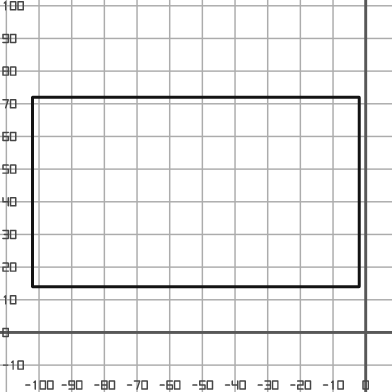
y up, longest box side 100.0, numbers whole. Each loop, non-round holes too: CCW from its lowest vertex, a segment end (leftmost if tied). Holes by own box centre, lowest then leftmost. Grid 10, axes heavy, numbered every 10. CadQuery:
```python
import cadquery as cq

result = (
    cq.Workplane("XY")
    .moveTo(-102.0, 14.0)
    .lineTo(-2.0, 14.0)
    .lineTo(-2.0, 72.0)
    .lineTo(-102.0, 72.0)
    .close()
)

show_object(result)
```